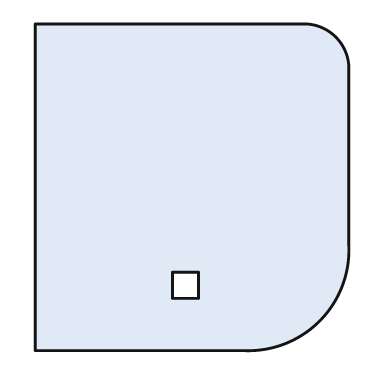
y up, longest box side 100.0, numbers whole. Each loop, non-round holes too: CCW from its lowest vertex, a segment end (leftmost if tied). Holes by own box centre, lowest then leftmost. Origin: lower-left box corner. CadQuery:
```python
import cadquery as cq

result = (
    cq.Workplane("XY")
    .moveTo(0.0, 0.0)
    .lineTo(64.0, 0.0)
    .threePointArc((87.0, 9.0), (96.0, 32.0))
    .lineTo(96.0, 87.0)
    .threePointArc((92.0, 96.0), (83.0, 100.0))
    .lineTo(0.0, 100.0)
    .close()
    .moveTo(42.0, 16.0)
    .lineTo(50.0, 16.0)
    .lineTo(50.0, 24.0)
    .lineTo(42.0, 24.0)
    .close()
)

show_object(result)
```